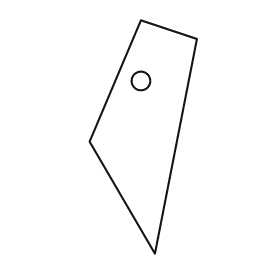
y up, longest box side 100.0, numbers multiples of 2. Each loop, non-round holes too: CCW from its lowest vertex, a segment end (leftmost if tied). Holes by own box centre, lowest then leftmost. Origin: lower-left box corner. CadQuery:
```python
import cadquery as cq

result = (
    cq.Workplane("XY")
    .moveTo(28.0, 0.0)
    .lineTo(46.0, 92.0)
    .lineTo(22.0, 100.0)
    .lineTo(0.0, 48.0)
    .close()
    .moveTo(22.0, 74.0)
    .circle(4.0)
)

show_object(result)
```